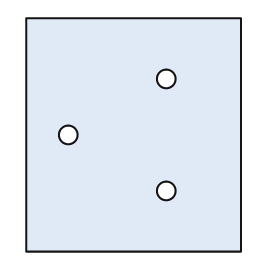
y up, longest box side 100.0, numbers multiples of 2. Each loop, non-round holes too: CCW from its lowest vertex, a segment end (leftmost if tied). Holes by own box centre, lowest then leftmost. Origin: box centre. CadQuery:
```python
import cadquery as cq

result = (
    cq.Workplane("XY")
    .moveTo(-46.0, -50.0)
    .lineTo(46.0, -50.0)
    .lineTo(46.0, 50.0)
    .lineTo(-46.0, 50.0)
    .close()
    .moveTo(14.0, -24.0)
    .circle(4.0)
    .moveTo(-28.0, 0.0)
    .circle(4.0)
    .moveTo(14.0, 24.0)
    .circle(4.0)
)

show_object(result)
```